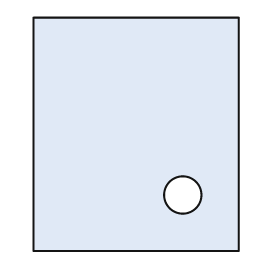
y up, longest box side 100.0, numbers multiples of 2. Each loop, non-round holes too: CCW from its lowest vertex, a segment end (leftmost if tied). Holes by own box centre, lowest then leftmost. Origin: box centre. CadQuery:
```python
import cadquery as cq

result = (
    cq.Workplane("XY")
    .moveTo(-44.0, -50.0)
    .lineTo(44.0, -50.0)
    .lineTo(44.0, 50.0)
    .lineTo(-44.0, 50.0)
    .close()
    .moveTo(20.0, -26.0)
    .circle(8.0)
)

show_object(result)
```